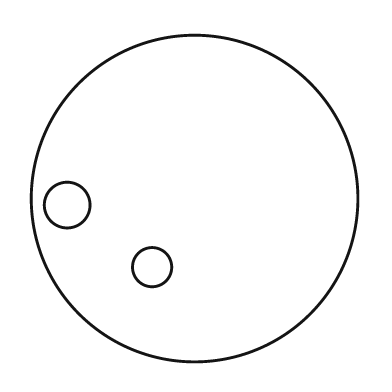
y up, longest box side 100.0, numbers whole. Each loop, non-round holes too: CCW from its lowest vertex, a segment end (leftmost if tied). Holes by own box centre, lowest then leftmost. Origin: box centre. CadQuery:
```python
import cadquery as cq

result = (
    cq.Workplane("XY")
    .moveTo(0.0, 0.0)
    .circle(50.0)
    .moveTo(-13.0, -21.0)
    .circle(6.0)
    .moveTo(-39.0, -2.0)
    .circle(7.0)
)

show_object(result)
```